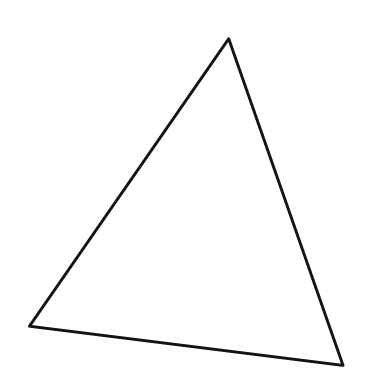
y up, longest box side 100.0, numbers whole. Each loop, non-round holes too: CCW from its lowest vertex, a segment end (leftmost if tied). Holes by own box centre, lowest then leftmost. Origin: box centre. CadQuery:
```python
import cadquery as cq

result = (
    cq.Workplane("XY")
    .moveTo(48.0, -50.0)
    .lineTo(13.0, 50.0)
    .lineTo(-48.0, -38.0)
    .close()
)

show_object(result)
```